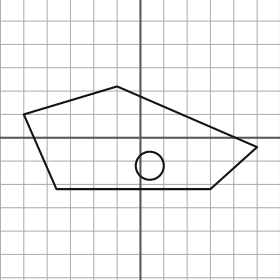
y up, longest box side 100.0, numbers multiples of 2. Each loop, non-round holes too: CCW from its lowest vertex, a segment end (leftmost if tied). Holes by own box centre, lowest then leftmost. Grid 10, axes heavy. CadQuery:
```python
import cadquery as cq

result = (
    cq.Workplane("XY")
    .moveTo(-36.0, -22.0)
    .lineTo(30.0, -22.0)
    .lineTo(50.0, -4.0)
    .lineTo(-10.0, 22.0)
    .lineTo(-50.0, 10.0)
    .close()
    .moveTo(4.0, -12.0)
    .circle(6.0)
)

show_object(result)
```